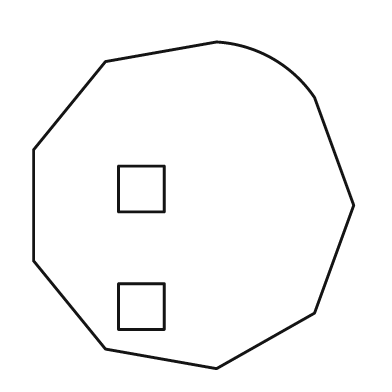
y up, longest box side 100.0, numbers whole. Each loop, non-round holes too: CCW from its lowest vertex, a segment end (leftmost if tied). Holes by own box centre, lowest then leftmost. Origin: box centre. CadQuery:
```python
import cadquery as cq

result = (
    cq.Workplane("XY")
    .moveTo(7.0, -50.0)
    .lineTo(37.0, -33.0)
    .lineTo(49.0, 0.0)
    .lineTo(37.0, 33.0)
    .threePointArc((24.0, 45.0), (7.0, 50.0))
    .lineTo(-27.0, 44.0)
    .lineTo(-49.0, 17.0)
    .lineTo(-49.0, -17.0)
    .lineTo(-27.0, -44.0)
    .close()
    .moveTo(-23.0, -38.0)
    .lineTo(-9.0, -38.0)
    .lineTo(-9.0, -24.0)
    .lineTo(-23.0, -24.0)
    .close()
    .moveTo(-23.0, -2.0)
    .lineTo(-9.0, -2.0)
    .lineTo(-9.0, 12.0)
    .lineTo(-23.0, 12.0)
    .close()
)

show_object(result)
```